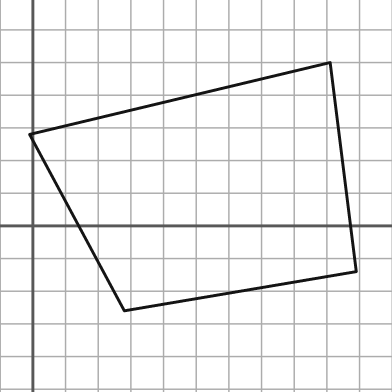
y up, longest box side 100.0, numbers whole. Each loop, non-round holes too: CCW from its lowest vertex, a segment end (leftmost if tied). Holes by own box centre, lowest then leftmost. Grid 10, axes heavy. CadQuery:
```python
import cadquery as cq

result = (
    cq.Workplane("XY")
    .moveTo(28.0, -26.0)
    .lineTo(99.0, -14.0)
    .lineTo(91.0, 50.0)
    .lineTo(-1.0, 28.0)
    .close()
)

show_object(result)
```